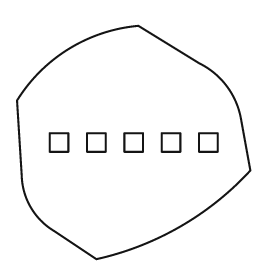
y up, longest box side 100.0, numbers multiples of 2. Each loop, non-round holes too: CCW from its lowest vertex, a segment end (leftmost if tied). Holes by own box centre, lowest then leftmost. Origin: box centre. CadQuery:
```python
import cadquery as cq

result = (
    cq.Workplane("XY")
    .moveTo(-16.0, -50.0)
    .threePointArc((20.0, -36.0), (50.0, -12.0))
    .lineTo(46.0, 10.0)
    .threePointArc((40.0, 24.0), (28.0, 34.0))
    .lineTo(2.0, 50.0)
    .threePointArc((-28.0, 40.0), (-50.0, 18.0))
    .lineTo(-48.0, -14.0)
    .threePointArc((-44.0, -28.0), (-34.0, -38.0))
    .close()
    .moveTo(-36.0, -4.0)
    .lineTo(-28.0, -4.0)
    .lineTo(-28.0, 4.0)
    .lineTo(-36.0, 4.0)
    .close()
    .moveTo(-20.0, -4.0)
    .lineTo(-12.0, -4.0)
    .lineTo(-12.0, 4.0)
    .lineTo(-20.0, 4.0)
    .close()
    .moveTo(-4.0, -4.0)
    .lineTo(4.0, -4.0)
    .lineTo(4.0, 4.0)
    .lineTo(-4.0, 4.0)
    .close()
    .moveTo(12.0, -4.0)
    .lineTo(20.0, -4.0)
    .lineTo(20.0, 4.0)
    .lineTo(12.0, 4.0)
    .close()
    .moveTo(28.0, -4.0)
    .lineTo(36.0, -4.0)
    .lineTo(36.0, 4.0)
    .lineTo(28.0, 4.0)
    .close()
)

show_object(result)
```